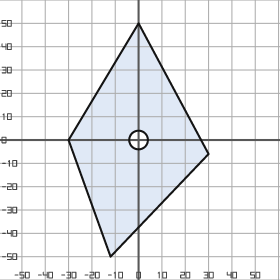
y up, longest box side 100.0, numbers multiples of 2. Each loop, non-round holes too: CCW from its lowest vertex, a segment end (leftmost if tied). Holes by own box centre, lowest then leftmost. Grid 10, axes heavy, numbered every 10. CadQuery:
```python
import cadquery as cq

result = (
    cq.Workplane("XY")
    .moveTo(-12.0, -50.0)
    .lineTo(30.0, -6.0)
    .lineTo(0.0, 50.0)
    .lineTo(-30.0, 0.0)
    .close()
    .moveTo(0.0, 0.0)
    .circle(4.0)
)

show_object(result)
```